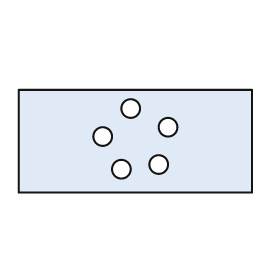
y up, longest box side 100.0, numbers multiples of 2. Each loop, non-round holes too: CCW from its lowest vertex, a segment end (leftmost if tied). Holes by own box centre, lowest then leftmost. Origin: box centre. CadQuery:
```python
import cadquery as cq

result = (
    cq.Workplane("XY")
    .moveTo(-50.0, -22.0)
    .lineTo(50.0, -22.0)
    .lineTo(50.0, 22.0)
    .lineTo(-50.0, 22.0)
    .close()
    .moveTo(-6.0, -12.0)
    .circle(4.0)
    .moveTo(10.0, -10.0)
    .circle(4.0)
    .moveTo(-14.0, 2.0)
    .circle(4.0)
    .moveTo(14.0, 6.0)
    .circle(4.0)
    .moveTo(-2.0, 14.0)
    .circle(4.0)
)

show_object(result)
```